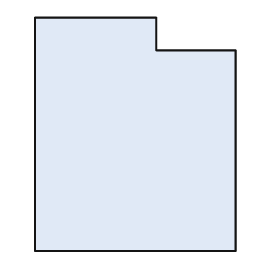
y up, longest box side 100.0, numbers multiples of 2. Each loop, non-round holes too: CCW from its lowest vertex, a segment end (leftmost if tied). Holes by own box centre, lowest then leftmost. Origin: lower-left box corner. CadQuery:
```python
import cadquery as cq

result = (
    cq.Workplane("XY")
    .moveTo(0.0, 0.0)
    .lineTo(86.0, 0.0)
    .lineTo(86.0, 86.0)
    .lineTo(52.0, 86.0)
    .lineTo(52.0, 100.0)
    .lineTo(0.0, 100.0)
    .close()
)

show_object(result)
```